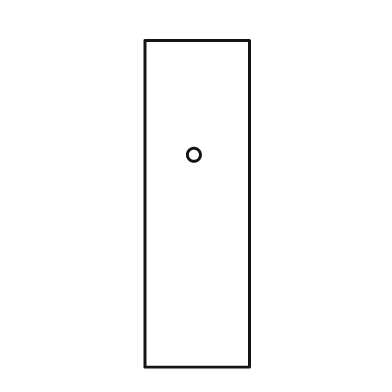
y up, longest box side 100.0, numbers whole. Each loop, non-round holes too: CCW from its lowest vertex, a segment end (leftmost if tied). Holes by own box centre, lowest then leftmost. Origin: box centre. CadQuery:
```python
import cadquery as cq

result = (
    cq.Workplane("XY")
    .moveTo(-16.0, -50.0)
    .lineTo(16.0, -50.0)
    .lineTo(16.0, 50.0)
    .lineTo(-16.0, 50.0)
    .close()
    .moveTo(-1.0, 15.0)
    .circle(2.0)
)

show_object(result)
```